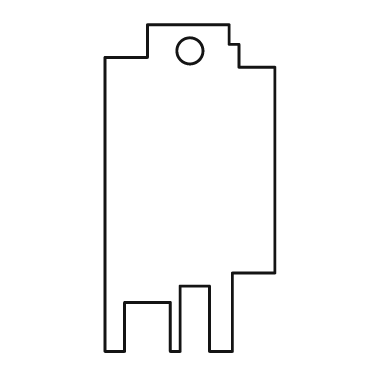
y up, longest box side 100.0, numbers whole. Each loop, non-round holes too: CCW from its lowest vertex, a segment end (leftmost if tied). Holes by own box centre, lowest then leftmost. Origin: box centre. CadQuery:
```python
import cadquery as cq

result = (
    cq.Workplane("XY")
    .moveTo(-26.0, -50.0)
    .lineTo(-20.0, -50.0)
    .lineTo(-20.0, -35.0)
    .lineTo(-6.0, -35.0)
    .lineTo(-6.0, -50.0)
    .lineTo(-3.0, -50.0)
    .lineTo(-3.0, -30.0)
    .lineTo(6.0, -30.0)
    .lineTo(6.0, -50.0)
    .lineTo(13.0, -50.0)
    .lineTo(13.0, -26.0)
    .lineTo(26.0, -26.0)
    .lineTo(26.0, 37.0)
    .lineTo(15.0, 37.0)
    .lineTo(15.0, 44.0)
    .lineTo(12.0, 44.0)
    .lineTo(12.0, 50.0)
    .lineTo(-13.0, 50.0)
    .lineTo(-13.0, 40.0)
    .lineTo(-26.0, 40.0)
    .close()
    .moveTo(0.0, 42.0)
    .circle(4.0)
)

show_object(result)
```